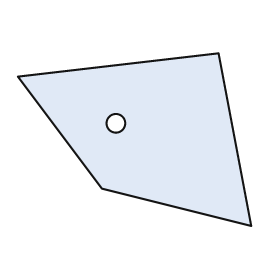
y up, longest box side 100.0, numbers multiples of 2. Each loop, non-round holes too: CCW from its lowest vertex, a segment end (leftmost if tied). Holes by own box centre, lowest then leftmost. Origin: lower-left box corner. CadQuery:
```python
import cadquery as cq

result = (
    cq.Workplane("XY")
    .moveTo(100.0, 0.0)
    .lineTo(86.0, 74.0)
    .lineTo(0.0, 64.0)
    .lineTo(36.0, 16.0)
    .close()
    .moveTo(42.0, 44.0)
    .circle(4.0)
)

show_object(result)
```